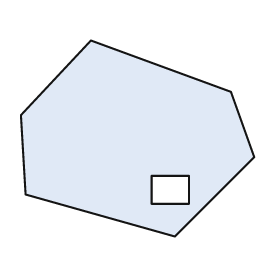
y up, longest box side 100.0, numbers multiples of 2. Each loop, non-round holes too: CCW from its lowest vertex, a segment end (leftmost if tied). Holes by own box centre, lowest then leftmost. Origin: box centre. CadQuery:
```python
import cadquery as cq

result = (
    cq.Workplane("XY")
    .moveTo(16.0, -42.0)
    .lineTo(50.0, -8.0)
    .lineTo(40.0, 20.0)
    .lineTo(-20.0, 42.0)
    .lineTo(-50.0, 10.0)
    .lineTo(-48.0, -24.0)
    .close()
    .moveTo(6.0, -28.0)
    .lineTo(22.0, -28.0)
    .lineTo(22.0, -16.0)
    .lineTo(6.0, -16.0)
    .close()
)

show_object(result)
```